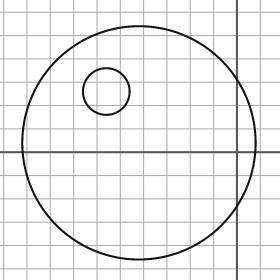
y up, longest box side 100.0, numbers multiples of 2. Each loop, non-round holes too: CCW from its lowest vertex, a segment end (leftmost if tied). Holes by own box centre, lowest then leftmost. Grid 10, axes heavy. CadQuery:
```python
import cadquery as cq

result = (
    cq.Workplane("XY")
    .moveTo(-42.0, 4.0)
    .circle(50.0)
    .moveTo(-56.0, 26.0)
    .circle(10.0)
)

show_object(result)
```